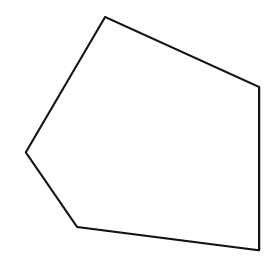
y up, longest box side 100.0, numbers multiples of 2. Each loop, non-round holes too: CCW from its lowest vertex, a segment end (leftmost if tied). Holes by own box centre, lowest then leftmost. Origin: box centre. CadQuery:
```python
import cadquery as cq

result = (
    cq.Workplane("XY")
    .moveTo(50.0, -50.0)
    .lineTo(50.0, 20.0)
    .lineTo(-16.0, 50.0)
    .lineTo(-50.0, -8.0)
    .lineTo(-28.0, -40.0)
    .close()
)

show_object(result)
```